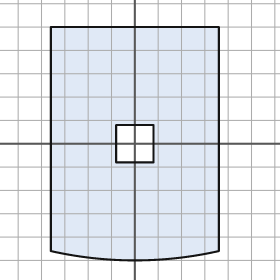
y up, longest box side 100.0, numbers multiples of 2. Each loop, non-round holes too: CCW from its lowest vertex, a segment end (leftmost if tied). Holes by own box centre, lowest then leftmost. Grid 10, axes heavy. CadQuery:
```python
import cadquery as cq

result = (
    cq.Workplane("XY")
    .moveTo(-36.0, -46.0)
    .threePointArc((0.0, -50.0), (36.0, -46.0))
    .lineTo(36.0, 50.0)
    .lineTo(-36.0, 50.0)
    .close()
    .moveTo(-8.0, -8.0)
    .lineTo(8.0, -8.0)
    .lineTo(8.0, 8.0)
    .lineTo(-8.0, 8.0)
    .close()
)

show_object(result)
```